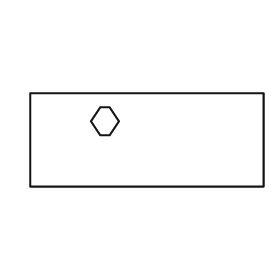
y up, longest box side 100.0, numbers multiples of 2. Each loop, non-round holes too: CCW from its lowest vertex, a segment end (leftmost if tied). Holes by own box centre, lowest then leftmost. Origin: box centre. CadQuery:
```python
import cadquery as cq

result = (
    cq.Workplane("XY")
    .moveTo(-50.0, -20.0)
    .lineTo(50.0, -20.0)
    .lineTo(50.0, 20.0)
    .lineTo(-50.0, 20.0)
    .close()
    .moveTo(-20.0, 2.0)
    .lineTo(-16.0, 2.0)
    .lineTo(-12.0, 8.0)
    .lineTo(-16.0, 14.0)
    .lineTo(-20.0, 14.0)
    .lineTo(-24.0, 8.0)
    .close()
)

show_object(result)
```